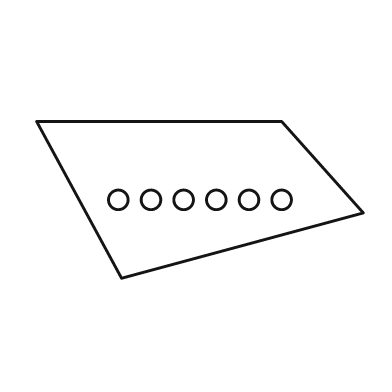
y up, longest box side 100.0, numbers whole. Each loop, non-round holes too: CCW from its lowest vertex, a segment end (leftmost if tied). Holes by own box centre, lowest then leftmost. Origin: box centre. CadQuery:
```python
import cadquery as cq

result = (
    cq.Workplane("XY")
    .moveTo(-24.0, -24.0)
    .lineTo(50.0, -4.0)
    .lineTo(25.0, 24.0)
    .lineTo(-50.0, 24.0)
    .close()
    .moveTo(-25.0, 0.0)
    .circle(3.0)
    .moveTo(-15.0, 0.0)
    .circle(3.0)
    .moveTo(-5.0, 0.0)
    .circle(3.0)
    .moveTo(5.0, 0.0)
    .circle(3.0)
    .moveTo(15.0, 0.0)
    .circle(3.0)
    .moveTo(25.0, 0.0)
    .circle(3.0)
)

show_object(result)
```